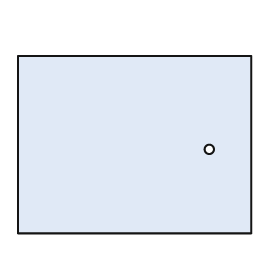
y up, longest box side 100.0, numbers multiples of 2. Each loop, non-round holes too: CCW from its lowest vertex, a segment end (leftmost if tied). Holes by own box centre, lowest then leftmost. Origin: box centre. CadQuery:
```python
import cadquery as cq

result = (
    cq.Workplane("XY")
    .moveTo(-50.0, -38.0)
    .lineTo(50.0, -38.0)
    .lineTo(50.0, 38.0)
    .lineTo(-50.0, 38.0)
    .close()
    .moveTo(32.0, -2.0)
    .circle(2.0)
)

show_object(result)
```